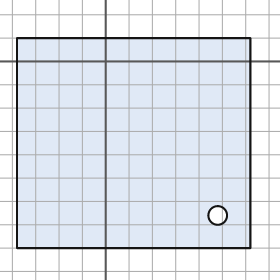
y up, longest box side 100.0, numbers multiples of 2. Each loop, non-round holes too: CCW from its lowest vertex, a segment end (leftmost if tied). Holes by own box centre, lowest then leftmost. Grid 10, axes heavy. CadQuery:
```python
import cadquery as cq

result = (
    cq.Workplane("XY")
    .moveTo(-38.0, -80.0)
    .lineTo(62.0, -80.0)
    .lineTo(62.0, 10.0)
    .lineTo(-38.0, 10.0)
    .close()
    .moveTo(48.0, -66.0)
    .circle(4.0)
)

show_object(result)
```